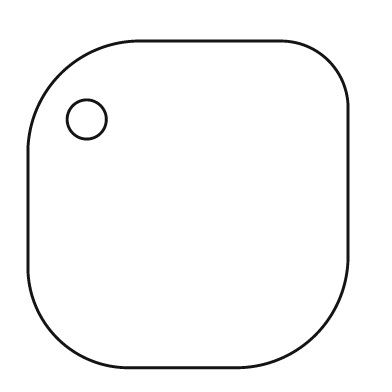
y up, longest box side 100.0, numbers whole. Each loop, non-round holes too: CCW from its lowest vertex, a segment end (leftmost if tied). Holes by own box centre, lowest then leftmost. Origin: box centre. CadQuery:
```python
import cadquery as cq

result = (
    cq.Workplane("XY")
    .moveTo(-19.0, -50.0)
    .lineTo(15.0, -50.0)
    .threePointArc((39.0, -40.0), (49.0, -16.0))
    .lineTo(49.0, 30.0)
    .threePointArc((43.0, 44.0), (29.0, 50.0))
    .lineTo(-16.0, 50.0)
    .threePointArc((-39.0, 40.0), (-49.0, 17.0))
    .lineTo(-49.0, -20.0)
    .threePointArc((-40.0, -41.0), (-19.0, -50.0))
    .close()
    .moveTo(-31.0, 26.0)
    .circle(6.0)
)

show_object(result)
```